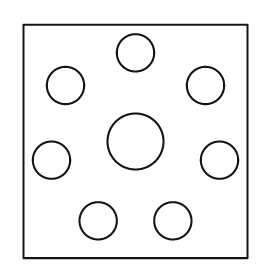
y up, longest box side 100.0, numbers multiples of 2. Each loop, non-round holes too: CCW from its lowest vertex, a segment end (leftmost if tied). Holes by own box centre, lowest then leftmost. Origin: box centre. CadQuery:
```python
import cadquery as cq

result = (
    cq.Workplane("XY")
    .moveTo(-48.0, -50.0)
    .lineTo(48.0, -50.0)
    .lineTo(48.0, 50.0)
    .lineTo(-48.0, 50.0)
    .close()
    .moveTo(-16.0, -34.0)
    .circle(8.0)
    .moveTo(16.0, -34.0)
    .circle(8.0)
    .moveTo(-36.0, -8.0)
    .circle(8.0)
    .moveTo(36.0, -8.0)
    .circle(8.0)
    .moveTo(0.0, 0.0)
    .circle(12.0)
    .moveTo(-30.0, 24.0)
    .circle(8.0)
    .moveTo(30.0, 24.0)
    .circle(8.0)
    .moveTo(0.0, 38.0)
    .circle(8.0)
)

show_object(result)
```